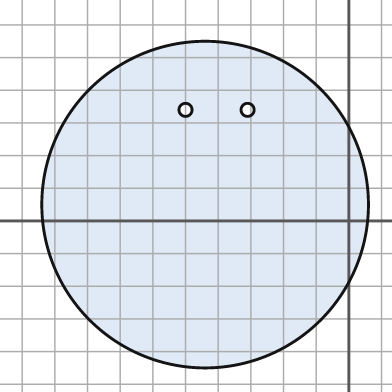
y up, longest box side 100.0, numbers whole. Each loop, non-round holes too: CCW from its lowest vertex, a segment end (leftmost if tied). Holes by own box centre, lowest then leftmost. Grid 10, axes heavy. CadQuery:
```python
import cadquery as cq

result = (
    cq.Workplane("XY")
    .moveTo(-44.0, 5.0)
    .circle(50.0)
    .moveTo(-50.0, 34.0)
    .circle(2.0)
    .moveTo(-31.0, 34.0)
    .circle(2.0)
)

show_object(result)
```